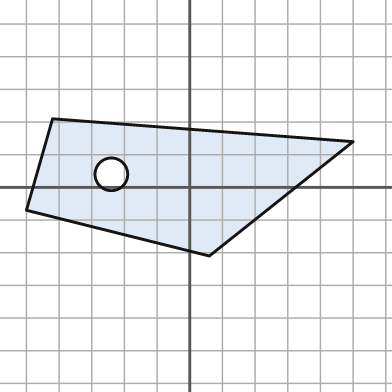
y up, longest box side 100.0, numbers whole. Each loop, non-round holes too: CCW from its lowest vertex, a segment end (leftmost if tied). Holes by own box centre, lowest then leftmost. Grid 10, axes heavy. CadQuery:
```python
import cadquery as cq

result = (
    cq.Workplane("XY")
    .moveTo(6.0, -21.0)
    .lineTo(50.0, 14.0)
    .lineTo(-42.0, 21.0)
    .lineTo(-50.0, -7.0)
    .close()
    .moveTo(-24.0, 4.0)
    .circle(5.0)
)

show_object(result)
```